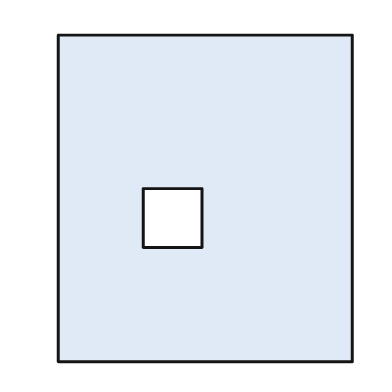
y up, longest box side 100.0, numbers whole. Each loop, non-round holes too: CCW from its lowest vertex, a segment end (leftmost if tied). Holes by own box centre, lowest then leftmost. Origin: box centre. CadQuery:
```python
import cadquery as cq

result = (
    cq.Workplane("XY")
    .moveTo(-45.0, -50.0)
    .lineTo(45.0, -50.0)
    .lineTo(45.0, 50.0)
    .lineTo(-45.0, 50.0)
    .close()
    .moveTo(-19.0, -15.0)
    .lineTo(-1.0, -15.0)
    .lineTo(-1.0, 3.0)
    .lineTo(-19.0, 3.0)
    .close()
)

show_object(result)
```